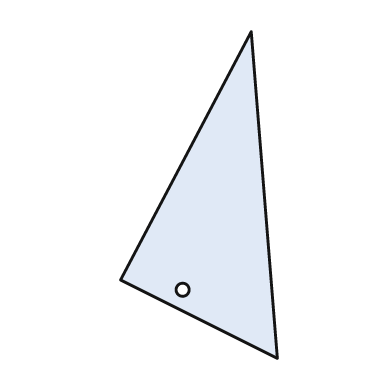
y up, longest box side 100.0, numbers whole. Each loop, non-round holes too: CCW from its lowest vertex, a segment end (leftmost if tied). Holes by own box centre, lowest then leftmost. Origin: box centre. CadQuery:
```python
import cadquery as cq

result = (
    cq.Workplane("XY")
    .moveTo(24.0, -50.0)
    .lineTo(16.0, 50.0)
    .lineTo(-24.0, -26.0)
    .close()
    .moveTo(-5.0, -29.0)
    .circle(2.0)
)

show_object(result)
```